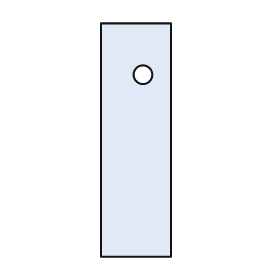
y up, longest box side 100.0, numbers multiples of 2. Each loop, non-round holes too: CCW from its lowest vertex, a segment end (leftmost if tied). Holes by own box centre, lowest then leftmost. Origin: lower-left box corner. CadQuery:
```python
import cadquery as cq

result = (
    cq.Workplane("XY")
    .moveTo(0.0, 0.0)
    .lineTo(30.0, 0.0)
    .lineTo(30.0, 100.0)
    .lineTo(0.0, 100.0)
    .close()
    .moveTo(18.0, 78.0)
    .circle(4.0)
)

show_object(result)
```